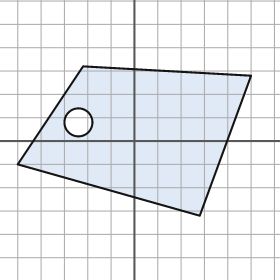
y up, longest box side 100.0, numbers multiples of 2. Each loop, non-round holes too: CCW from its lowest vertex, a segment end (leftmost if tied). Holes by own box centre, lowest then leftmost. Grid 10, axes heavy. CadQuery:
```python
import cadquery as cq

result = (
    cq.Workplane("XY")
    .moveTo(28.0, -32.0)
    .lineTo(50.0, 28.0)
    .lineTo(-22.0, 32.0)
    .lineTo(-50.0, -10.0)
    .close()
    .moveTo(-24.0, 8.0)
    .circle(6.0)
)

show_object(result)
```